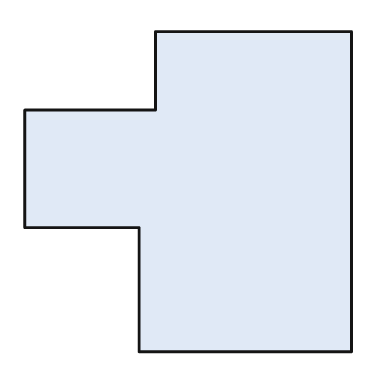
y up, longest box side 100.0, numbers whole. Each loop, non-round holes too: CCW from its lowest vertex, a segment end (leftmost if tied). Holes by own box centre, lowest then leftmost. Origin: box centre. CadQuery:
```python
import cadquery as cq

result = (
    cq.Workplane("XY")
    .moveTo(-15.0, -49.0)
    .lineTo(50.0, -49.0)
    .lineTo(50.0, 49.0)
    .lineTo(-10.0, 49.0)
    .lineTo(-10.0, 25.0)
    .lineTo(-50.0, 25.0)
    .lineTo(-50.0, -11.0)
    .lineTo(-15.0, -11.0)
    .close()
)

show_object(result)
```